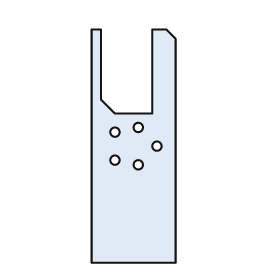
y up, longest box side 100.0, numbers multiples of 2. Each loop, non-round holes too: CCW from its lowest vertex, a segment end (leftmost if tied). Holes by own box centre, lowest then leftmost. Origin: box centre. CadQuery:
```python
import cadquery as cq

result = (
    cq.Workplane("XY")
    .moveTo(-18.0, -50.0)
    .lineTo(18.0, -50.0)
    .lineTo(18.0, 46.0)
    .lineTo(14.0, 50.0)
    .lineTo(8.0, 50.0)
    .lineTo(8.0, 14.0)
    .lineTo(-8.0, 14.0)
    .lineTo(-14.0, 20.0)
    .lineTo(-14.0, 50.0)
    .lineTo(-18.0, 50.0)
    .close()
    .moveTo(2.0, -8.0)
    .circle(2.0)
    .moveTo(-8.0, -6.0)
    .circle(2.0)
    .moveTo(10.0, 0.0)
    .circle(2.0)
    .moveTo(-8.0, 6.0)
    .circle(2.0)
    .moveTo(2.0, 8.0)
    .circle(2.0)
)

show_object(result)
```